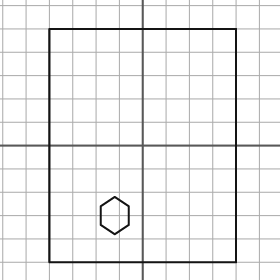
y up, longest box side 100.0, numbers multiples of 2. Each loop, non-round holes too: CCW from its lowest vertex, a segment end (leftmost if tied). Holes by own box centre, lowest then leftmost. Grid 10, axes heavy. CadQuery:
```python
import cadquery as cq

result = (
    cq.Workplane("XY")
    .moveTo(-40.0, -50.0)
    .lineTo(40.0, -50.0)
    .lineTo(40.0, 50.0)
    .lineTo(-40.0, 50.0)
    .close()
    .moveTo(-12.0, -38.0)
    .lineTo(-6.0, -34.0)
    .lineTo(-6.0, -26.0)
    .lineTo(-12.0, -22.0)
    .lineTo(-18.0, -26.0)
    .lineTo(-18.0, -34.0)
    .close()
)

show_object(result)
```